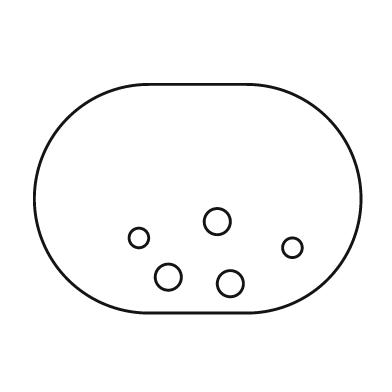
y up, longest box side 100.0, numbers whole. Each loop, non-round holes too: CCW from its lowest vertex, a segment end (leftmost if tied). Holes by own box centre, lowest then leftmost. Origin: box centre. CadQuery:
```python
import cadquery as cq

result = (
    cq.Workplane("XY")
    .moveTo(-15.0, -35.0)
    .lineTo(15.0, -35.0)
    .threePointArc((50.0, 0.0), (15.0, 35.0))
    .lineTo(-15.0, 35.0)
    .threePointArc((-50.0, 0.0), (-15.0, -35.0))
    .close()
    .moveTo(10.0, -26.0)
    .circle(4.0)
    .moveTo(-9.0, -24.0)
    .circle(4.0)
    .moveTo(29.0, -15.0)
    .circle(3.0)
    .moveTo(-18.0, -12.0)
    .circle(3.0)
    .moveTo(6.0, -7.0)
    .circle(4.0)
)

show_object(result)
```